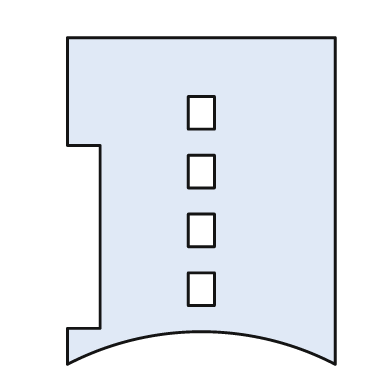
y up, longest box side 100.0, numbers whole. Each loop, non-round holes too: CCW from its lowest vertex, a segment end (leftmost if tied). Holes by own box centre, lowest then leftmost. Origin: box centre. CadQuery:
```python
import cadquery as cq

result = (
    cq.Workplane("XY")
    .moveTo(-41.0, -50.0)
    .threePointArc((0.0, -40.0), (41.0, -50.0))
    .lineTo(41.0, 50.0)
    .lineTo(-41.0, 50.0)
    .lineTo(-41.0, 17.0)
    .lineTo(-31.0, 17.0)
    .lineTo(-31.0, -39.0)
    .lineTo(-41.0, -39.0)
    .close()
    .moveTo(-4.0, -32.0)
    .lineTo(4.0, -32.0)
    .lineTo(4.0, -22.0)
    .lineTo(-4.0, -22.0)
    .close()
    .moveTo(-4.0, -14.0)
    .lineTo(4.0, -14.0)
    .lineTo(4.0, -4.0)
    .lineTo(-4.0, -4.0)
    .close()
    .moveTo(-4.0, 4.0)
    .lineTo(4.0, 4.0)
    .lineTo(4.0, 14.0)
    .lineTo(-4.0, 14.0)
    .close()
    .moveTo(-4.0, 22.0)
    .lineTo(4.0, 22.0)
    .lineTo(4.0, 32.0)
    .lineTo(-4.0, 32.0)
    .close()
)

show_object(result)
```